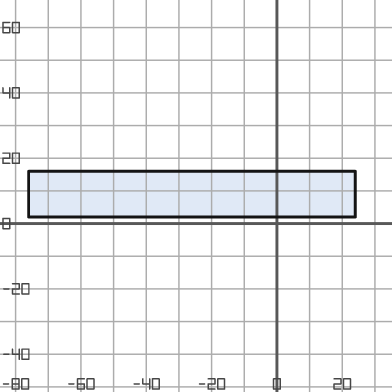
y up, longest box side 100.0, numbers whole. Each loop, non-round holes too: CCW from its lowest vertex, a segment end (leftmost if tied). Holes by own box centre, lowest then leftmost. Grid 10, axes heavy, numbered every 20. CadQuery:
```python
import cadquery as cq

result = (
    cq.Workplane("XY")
    .moveTo(-76.0, 2.0)
    .lineTo(24.0, 2.0)
    .lineTo(24.0, 16.0)
    .lineTo(-76.0, 16.0)
    .close()
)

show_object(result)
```